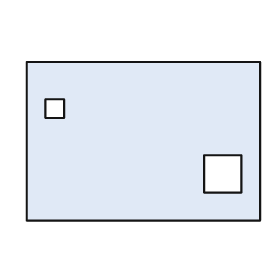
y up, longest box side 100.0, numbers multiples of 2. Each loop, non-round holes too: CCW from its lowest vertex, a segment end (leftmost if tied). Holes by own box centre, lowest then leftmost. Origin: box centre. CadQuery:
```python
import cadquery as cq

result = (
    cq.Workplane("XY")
    .moveTo(-50.0, -34.0)
    .lineTo(50.0, -34.0)
    .lineTo(50.0, 34.0)
    .lineTo(-50.0, 34.0)
    .close()
    .moveTo(26.0, -22.0)
    .lineTo(42.0, -22.0)
    .lineTo(42.0, -6.0)
    .lineTo(26.0, -6.0)
    .close()
    .moveTo(-42.0, 10.0)
    .lineTo(-34.0, 10.0)
    .lineTo(-34.0, 18.0)
    .lineTo(-42.0, 18.0)
    .close()
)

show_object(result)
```